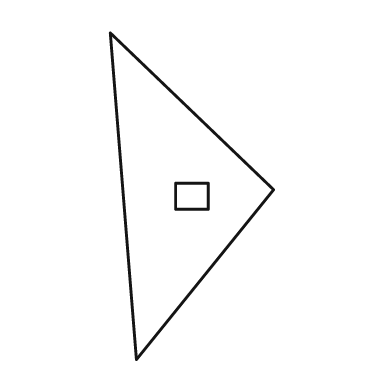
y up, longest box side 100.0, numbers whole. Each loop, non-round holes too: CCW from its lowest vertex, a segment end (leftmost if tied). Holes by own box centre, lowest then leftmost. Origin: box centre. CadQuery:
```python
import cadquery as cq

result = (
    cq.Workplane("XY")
    .moveTo(-17.0, -50.0)
    .lineTo(25.0, 2.0)
    .lineTo(-25.0, 50.0)
    .close()
    .moveTo(-5.0, -4.0)
    .lineTo(5.0, -4.0)
    .lineTo(5.0, 4.0)
    .lineTo(-5.0, 4.0)
    .close()
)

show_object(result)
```